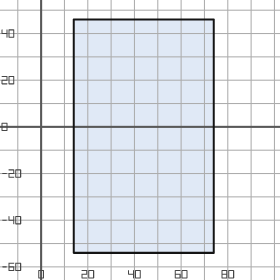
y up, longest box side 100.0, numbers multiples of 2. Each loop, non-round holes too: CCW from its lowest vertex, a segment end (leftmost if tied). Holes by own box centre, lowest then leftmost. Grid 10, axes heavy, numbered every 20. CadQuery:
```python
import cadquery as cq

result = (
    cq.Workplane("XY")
    .moveTo(14.0, -54.0)
    .lineTo(74.0, -54.0)
    .lineTo(74.0, 46.0)
    .lineTo(14.0, 46.0)
    .close()
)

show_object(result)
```